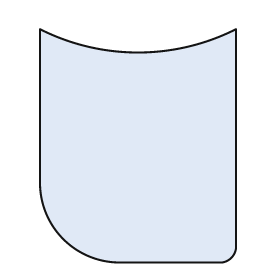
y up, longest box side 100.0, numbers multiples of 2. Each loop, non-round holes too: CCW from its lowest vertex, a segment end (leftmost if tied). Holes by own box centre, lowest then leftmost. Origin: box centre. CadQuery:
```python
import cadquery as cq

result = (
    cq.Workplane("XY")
    .moveTo(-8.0, -50.0)
    .lineTo(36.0, -50.0)
    .threePointArc((40.0, -48.0), (42.0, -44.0))
    .lineTo(42.0, 50.0)
    .threePointArc((0.0, 40.0), (-42.0, 50.0))
    .lineTo(-42.0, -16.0)
    .threePointArc((-32.0, -40.0), (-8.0, -50.0))
    .close()
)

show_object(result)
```